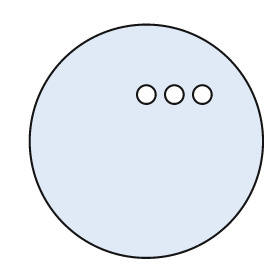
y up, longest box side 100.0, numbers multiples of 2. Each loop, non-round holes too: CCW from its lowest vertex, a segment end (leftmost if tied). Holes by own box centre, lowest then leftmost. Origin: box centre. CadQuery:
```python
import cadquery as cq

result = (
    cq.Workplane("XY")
    .moveTo(0.0, 0.0)
    .circle(50.0)
    .moveTo(0.0, 20.0)
    .circle(4.0)
    .moveTo(12.0, 20.0)
    .circle(4.0)
    .moveTo(24.0, 20.0)
    .circle(4.0)
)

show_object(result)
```